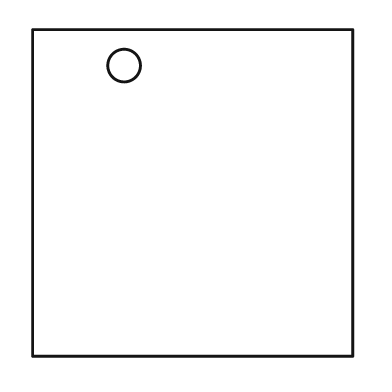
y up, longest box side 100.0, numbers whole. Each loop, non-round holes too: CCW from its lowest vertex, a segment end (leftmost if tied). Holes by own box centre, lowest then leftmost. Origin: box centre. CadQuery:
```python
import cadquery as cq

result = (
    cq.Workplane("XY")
    .moveTo(-49.0, -50.0)
    .lineTo(49.0, -50.0)
    .lineTo(49.0, 50.0)
    .lineTo(-49.0, 50.0)
    .close()
    .moveTo(-21.0, 39.0)
    .circle(5.0)
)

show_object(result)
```